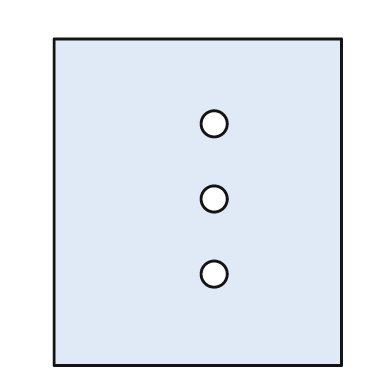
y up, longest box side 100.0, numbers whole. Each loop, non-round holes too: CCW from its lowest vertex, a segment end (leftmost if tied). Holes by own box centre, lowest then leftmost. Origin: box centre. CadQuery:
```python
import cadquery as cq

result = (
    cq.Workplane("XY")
    .moveTo(-44.0, -50.0)
    .lineTo(44.0, -50.0)
    .lineTo(44.0, 50.0)
    .lineTo(-44.0, 50.0)
    .close()
    .moveTo(5.0, -22.0)
    .circle(4.0)
    .moveTo(5.0, 1.0)
    .circle(4.0)
    .moveTo(5.0, 24.0)
    .circle(4.0)
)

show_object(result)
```